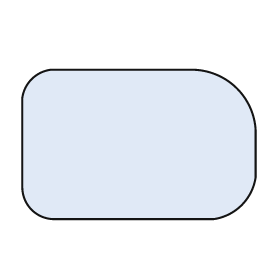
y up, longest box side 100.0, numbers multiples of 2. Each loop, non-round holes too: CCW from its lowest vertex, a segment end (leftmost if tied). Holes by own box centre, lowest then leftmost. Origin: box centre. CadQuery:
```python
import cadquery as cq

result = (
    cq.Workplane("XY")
    .moveTo(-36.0, -32.0)
    .lineTo(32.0, -32.0)
    .threePointArc((44.0, -26.0), (50.0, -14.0))
    .lineTo(50.0, 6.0)
    .threePointArc((42.0, 24.0), (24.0, 32.0))
    .lineTo(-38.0, 32.0)
    .threePointArc((-46.0, 28.0), (-50.0, 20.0))
    .lineTo(-50.0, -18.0)
    .threePointArc((-46.0, -28.0), (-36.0, -32.0))
    .close()
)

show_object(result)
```